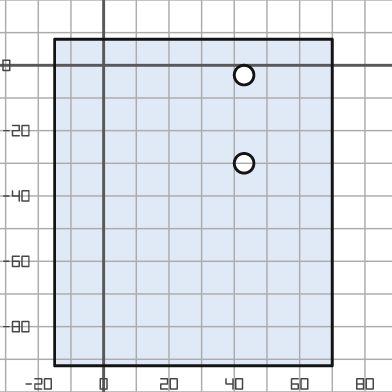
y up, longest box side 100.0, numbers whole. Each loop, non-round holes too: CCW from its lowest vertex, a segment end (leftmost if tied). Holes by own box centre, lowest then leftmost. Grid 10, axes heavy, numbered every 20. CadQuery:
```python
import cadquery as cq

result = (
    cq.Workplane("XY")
    .moveTo(-15.0, -92.0)
    .lineTo(70.0, -92.0)
    .lineTo(70.0, 8.0)
    .lineTo(-15.0, 8.0)
    .close()
    .moveTo(43.0, -30.0)
    .circle(3.0)
    .moveTo(43.0, -3.0)
    .circle(3.0)
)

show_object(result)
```